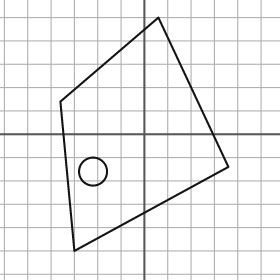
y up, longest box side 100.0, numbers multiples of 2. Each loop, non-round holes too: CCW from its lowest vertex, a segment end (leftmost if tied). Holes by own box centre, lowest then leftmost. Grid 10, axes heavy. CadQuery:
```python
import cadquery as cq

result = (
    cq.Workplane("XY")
    .moveTo(-30.0, -50.0)
    .lineTo(36.0, -14.0)
    .lineTo(6.0, 50.0)
    .lineTo(-36.0, 14.0)
    .close()
    .moveTo(-22.0, -16.0)
    .circle(6.0)
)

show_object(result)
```